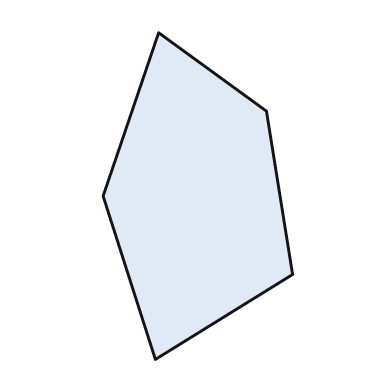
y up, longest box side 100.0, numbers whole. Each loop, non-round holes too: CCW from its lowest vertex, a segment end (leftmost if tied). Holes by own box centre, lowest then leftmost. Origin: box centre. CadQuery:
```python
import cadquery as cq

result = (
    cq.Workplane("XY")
    .moveTo(-13.0, -50.0)
    .lineTo(29.0, -24.0)
    .lineTo(21.0, 26.0)
    .lineTo(-12.0, 50.0)
    .lineTo(-29.0, 0.0)
    .close()
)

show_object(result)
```